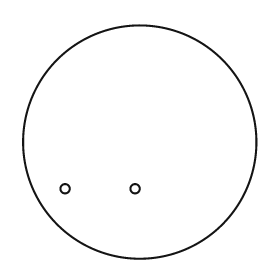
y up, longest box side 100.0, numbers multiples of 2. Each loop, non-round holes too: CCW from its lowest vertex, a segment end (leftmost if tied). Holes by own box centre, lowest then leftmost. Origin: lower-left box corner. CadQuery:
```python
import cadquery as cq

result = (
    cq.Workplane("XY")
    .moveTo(50.0, 50.0)
    .circle(50.0)
    .moveTo(18.0, 30.0)
    .circle(2.0)
    .moveTo(48.0, 30.0)
    .circle(2.0)
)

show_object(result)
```